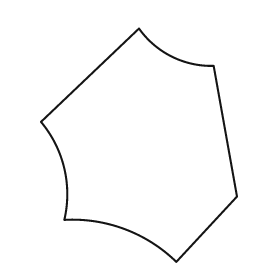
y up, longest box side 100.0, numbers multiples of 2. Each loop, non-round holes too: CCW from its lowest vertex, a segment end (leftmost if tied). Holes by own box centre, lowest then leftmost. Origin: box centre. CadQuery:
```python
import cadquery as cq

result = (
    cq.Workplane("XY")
    .moveTo(16.0, -50.0)
    .lineTo(42.0, -22.0)
    .lineTo(32.0, 34.0)
    .threePointArc((14.0, 38.0), (0.0, 50.0))
    .lineTo(-42.0, 10.0)
    .threePointArc((-32.0, -10.0), (-32.0, -32.0))
    .threePointArc((-6.0, -36.0), (16.0, -50.0))
    .close()
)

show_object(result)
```